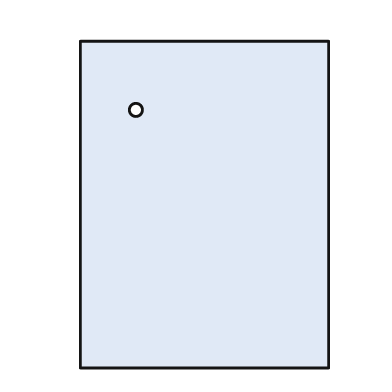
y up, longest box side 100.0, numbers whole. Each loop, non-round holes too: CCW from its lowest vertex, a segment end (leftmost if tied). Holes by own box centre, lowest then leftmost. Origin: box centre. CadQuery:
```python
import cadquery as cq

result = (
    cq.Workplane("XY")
    .moveTo(-38.0, -50.0)
    .lineTo(38.0, -50.0)
    .lineTo(38.0, 50.0)
    .lineTo(-38.0, 50.0)
    .close()
    .moveTo(-21.0, 29.0)
    .circle(2.0)
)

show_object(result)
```